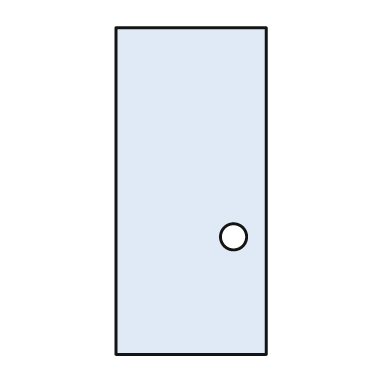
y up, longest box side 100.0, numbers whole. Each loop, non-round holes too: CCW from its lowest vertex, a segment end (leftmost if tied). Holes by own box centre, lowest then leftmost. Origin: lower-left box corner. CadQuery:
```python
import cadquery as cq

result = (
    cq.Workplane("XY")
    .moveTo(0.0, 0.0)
    .lineTo(46.0, 0.0)
    .lineTo(46.0, 100.0)
    .lineTo(0.0, 100.0)
    .close()
    .moveTo(36.0, 36.0)
    .circle(4.0)
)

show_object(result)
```